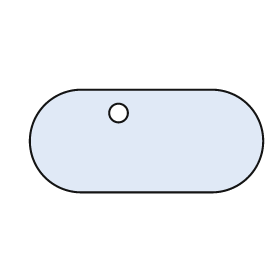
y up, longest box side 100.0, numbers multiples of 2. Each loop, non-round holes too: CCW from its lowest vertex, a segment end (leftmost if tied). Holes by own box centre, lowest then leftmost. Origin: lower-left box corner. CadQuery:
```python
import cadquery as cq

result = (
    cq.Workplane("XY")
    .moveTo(22.0, 0.0)
    .lineTo(78.0, 0.0)
    .threePointArc((100.0, 22.0), (78.0, 44.0))
    .lineTo(22.0, 44.0)
    .threePointArc((0.0, 22.0), (22.0, 0.0))
    .close()
    .moveTo(38.0, 34.0)
    .circle(4.0)
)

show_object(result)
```